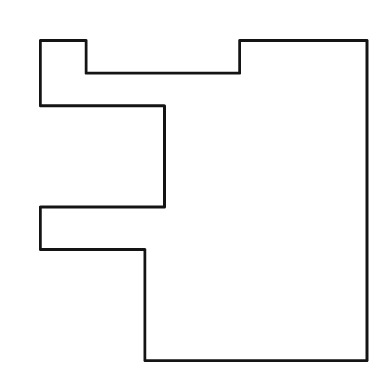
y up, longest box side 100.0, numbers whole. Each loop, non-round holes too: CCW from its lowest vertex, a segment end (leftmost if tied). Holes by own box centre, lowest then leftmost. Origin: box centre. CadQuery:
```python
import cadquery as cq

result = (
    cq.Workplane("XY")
    .moveTo(-18.0, -49.0)
    .lineTo(50.0, -49.0)
    .lineTo(50.0, 49.0)
    .lineTo(11.0, 49.0)
    .lineTo(11.0, 39.0)
    .lineTo(-36.0, 39.0)
    .lineTo(-36.0, 49.0)
    .lineTo(-50.0, 49.0)
    .lineTo(-50.0, 29.0)
    .lineTo(-12.0, 29.0)
    .lineTo(-12.0, -2.0)
    .lineTo(-50.0, -2.0)
    .lineTo(-50.0, -15.0)
    .lineTo(-18.0, -15.0)
    .close()
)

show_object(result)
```